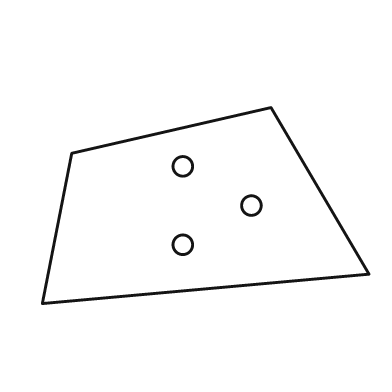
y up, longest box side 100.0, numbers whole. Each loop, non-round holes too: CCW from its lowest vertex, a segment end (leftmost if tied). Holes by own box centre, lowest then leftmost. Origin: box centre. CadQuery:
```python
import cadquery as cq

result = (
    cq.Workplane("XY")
    .moveTo(-50.0, -30.0)
    .lineTo(50.0, -21.0)
    .lineTo(20.0, 30.0)
    .lineTo(-41.0, 16.0)
    .close()
    .moveTo(-7.0, -12.0)
    .circle(3.0)
    .moveTo(14.0, 0.0)
    .circle(3.0)
    .moveTo(-7.0, 12.0)
    .circle(3.0)
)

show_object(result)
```